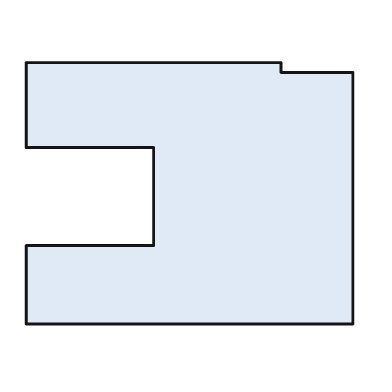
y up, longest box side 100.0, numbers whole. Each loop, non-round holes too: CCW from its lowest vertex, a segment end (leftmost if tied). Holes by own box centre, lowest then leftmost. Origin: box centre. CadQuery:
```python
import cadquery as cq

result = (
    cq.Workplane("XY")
    .moveTo(-50.0, -40.0)
    .lineTo(50.0, -40.0)
    .lineTo(50.0, 37.0)
    .lineTo(28.0, 37.0)
    .lineTo(28.0, 40.0)
    .lineTo(-50.0, 40.0)
    .lineTo(-50.0, 14.0)
    .lineTo(-11.0, 14.0)
    .lineTo(-11.0, -16.0)
    .lineTo(-50.0, -16.0)
    .close()
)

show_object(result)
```